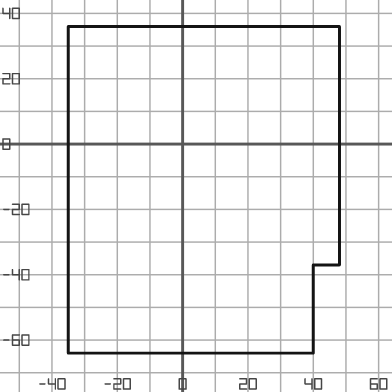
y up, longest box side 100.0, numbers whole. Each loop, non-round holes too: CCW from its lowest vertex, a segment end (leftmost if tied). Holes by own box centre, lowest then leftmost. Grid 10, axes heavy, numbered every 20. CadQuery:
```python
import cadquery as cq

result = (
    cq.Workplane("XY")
    .moveTo(-35.0, -64.0)
    .lineTo(40.0, -64.0)
    .lineTo(40.0, -37.0)
    .lineTo(48.0, -37.0)
    .lineTo(48.0, 36.0)
    .lineTo(-35.0, 36.0)
    .close()
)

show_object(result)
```